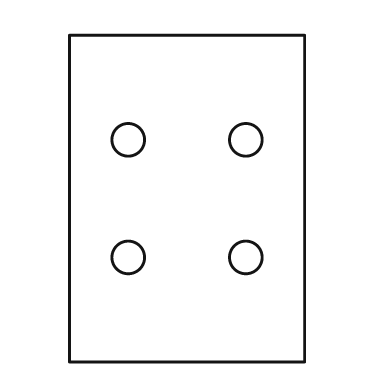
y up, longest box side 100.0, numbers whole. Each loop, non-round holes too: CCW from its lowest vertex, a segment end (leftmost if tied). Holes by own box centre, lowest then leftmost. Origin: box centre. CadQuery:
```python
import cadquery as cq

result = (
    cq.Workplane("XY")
    .moveTo(-36.0, -50.0)
    .lineTo(36.0, -50.0)
    .lineTo(36.0, 50.0)
    .lineTo(-36.0, 50.0)
    .close()
    .moveTo(-18.0, -18.0)
    .circle(5.0)
    .moveTo(18.0, -18.0)
    .circle(5.0)
    .moveTo(-18.0, 18.0)
    .circle(5.0)
    .moveTo(18.0, 18.0)
    .circle(5.0)
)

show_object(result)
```